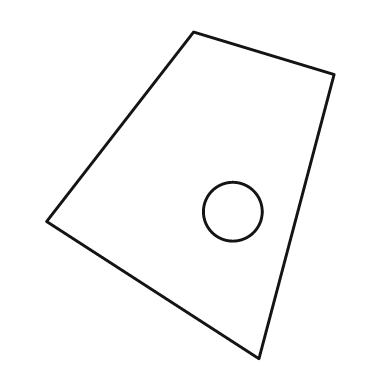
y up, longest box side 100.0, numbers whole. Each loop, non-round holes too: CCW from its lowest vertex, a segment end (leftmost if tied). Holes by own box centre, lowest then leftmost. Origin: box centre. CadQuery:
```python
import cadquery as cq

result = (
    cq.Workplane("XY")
    .moveTo(21.0, -50.0)
    .lineTo(44.0, 37.0)
    .lineTo(1.0, 50.0)
    .lineTo(-44.0, -8.0)
    .close()
    .moveTo(13.0, -5.0)
    .circle(9.0)
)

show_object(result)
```